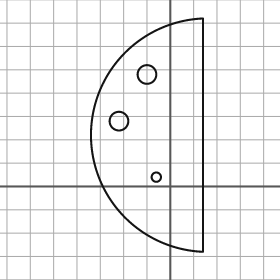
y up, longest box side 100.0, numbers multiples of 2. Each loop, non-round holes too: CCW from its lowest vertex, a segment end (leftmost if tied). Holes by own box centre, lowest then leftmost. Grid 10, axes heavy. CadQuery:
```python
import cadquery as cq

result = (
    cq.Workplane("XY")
    .moveTo(14.0, -28.0)
    .lineTo(14.0, 72.0)
    .threePointArc((-34.0, 22.0), (14.0, -28.0))
    .close()
    .moveTo(-6.0, 4.0)
    .circle(2.0)
    .moveTo(-22.0, 28.0)
    .circle(4.0)
    .moveTo(-10.0, 48.0)
    .circle(4.0)
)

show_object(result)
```